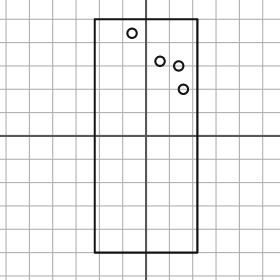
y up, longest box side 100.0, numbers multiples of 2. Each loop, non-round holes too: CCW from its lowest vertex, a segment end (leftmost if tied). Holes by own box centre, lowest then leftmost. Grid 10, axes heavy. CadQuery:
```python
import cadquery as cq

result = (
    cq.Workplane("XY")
    .moveTo(-22.0, -50.0)
    .lineTo(22.0, -50.0)
    .lineTo(22.0, 50.0)
    .lineTo(-22.0, 50.0)
    .close()
    .moveTo(16.0, 20.0)
    .circle(2.0)
    .moveTo(14.0, 30.0)
    .circle(2.0)
    .moveTo(6.0, 32.0)
    .circle(2.0)
    .moveTo(-6.0, 44.0)
    .circle(2.0)
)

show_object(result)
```